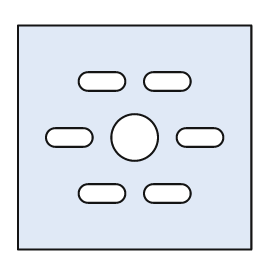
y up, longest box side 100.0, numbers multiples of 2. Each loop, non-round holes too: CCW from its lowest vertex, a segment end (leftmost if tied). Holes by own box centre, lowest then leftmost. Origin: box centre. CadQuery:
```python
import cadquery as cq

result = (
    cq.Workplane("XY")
    .moveTo(-50.0, -48.0)
    .lineTo(50.0, -48.0)
    .lineTo(50.0, 48.0)
    .lineTo(-50.0, 48.0)
    .close()
    .moveTo(-20.0, -28.0)
    .lineTo(-8.0, -28.0)
    .threePointArc((-4.0, -24.0), (-8.0, -20.0))
    .lineTo(-20.0, -20.0)
    .threePointArc((-24.0, -24.0), (-20.0, -28.0))
    .close()
    .moveTo(8.0, -28.0)
    .lineTo(20.0, -28.0)
    .threePointArc((24.0, -24.0), (20.0, -20.0))
    .lineTo(8.0, -20.0)
    .threePointArc((4.0, -24.0), (8.0, -28.0))
    .close()
    .moveTo(-34.0, -4.0)
    .lineTo(-22.0, -4.0)
    .threePointArc((-18.0, 0.0), (-22.0, 4.0))
    .lineTo(-34.0, 4.0)
    .threePointArc((-38.0, 0.0), (-34.0, -4.0))
    .close()
    .moveTo(0.0, 0.0)
    .circle(10.0)
    .moveTo(22.0, -4.0)
    .lineTo(34.0, -4.0)
    .threePointArc((38.0, 0.0), (34.0, 4.0))
    .lineTo(22.0, 4.0)
    .threePointArc((18.0, 0.0), (22.0, -4.0))
    .close()
    .moveTo(-20.0, 20.0)
    .lineTo(-8.0, 20.0)
    .threePointArc((-4.0, 24.0), (-8.0, 28.0))
    .lineTo(-20.0, 28.0)
    .threePointArc((-24.0, 24.0), (-20.0, 20.0))
    .close()
    .moveTo(8.0, 20.0)
    .lineTo(20.0, 20.0)
    .threePointArc((24.0, 24.0), (20.0, 28.0))
    .lineTo(8.0, 28.0)
    .threePointArc((4.0, 24.0), (8.0, 20.0))
    .close()
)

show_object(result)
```